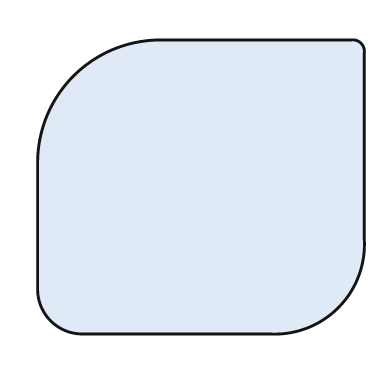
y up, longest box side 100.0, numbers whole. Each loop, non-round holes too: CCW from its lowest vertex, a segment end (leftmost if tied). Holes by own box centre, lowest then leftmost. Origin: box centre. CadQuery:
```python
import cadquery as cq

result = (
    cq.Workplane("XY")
    .moveTo(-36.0, -45.0)
    .lineTo(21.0, -45.0)
    .threePointArc((42.0, -37.0), (50.0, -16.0))
    .lineTo(50.0, 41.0)
    .threePointArc((49.0, 44.0), (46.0, 45.0))
    .lineTo(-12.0, 45.0)
    .threePointArc((-39.0, 34.0), (-50.0, 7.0))
    .lineTo(-50.0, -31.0)
    .threePointArc((-46.0, -41.0), (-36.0, -45.0))
    .close()
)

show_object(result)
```